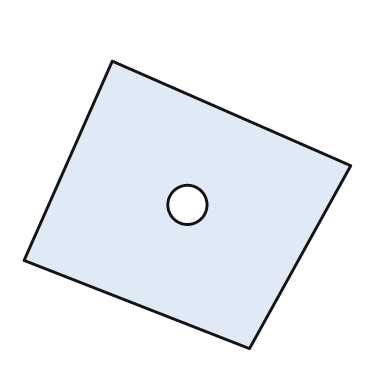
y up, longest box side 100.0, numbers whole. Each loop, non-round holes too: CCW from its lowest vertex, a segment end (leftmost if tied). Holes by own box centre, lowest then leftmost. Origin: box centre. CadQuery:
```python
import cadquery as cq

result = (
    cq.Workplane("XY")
    .moveTo(19.0, -44.0)
    .lineTo(50.0, 12.0)
    .lineTo(-23.0, 44.0)
    .lineTo(-50.0, -17.0)
    .close()
    .moveTo(0.0, 0.0)
    .circle(6.0)
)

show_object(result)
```